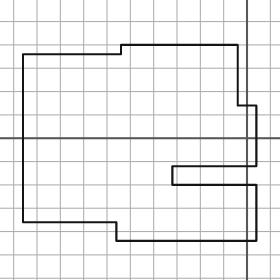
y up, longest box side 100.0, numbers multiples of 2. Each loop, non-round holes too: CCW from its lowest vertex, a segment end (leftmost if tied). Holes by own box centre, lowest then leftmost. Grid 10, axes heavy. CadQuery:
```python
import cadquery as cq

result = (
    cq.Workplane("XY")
    .moveTo(-56.0, -44.0)
    .lineTo(4.0, -44.0)
    .lineTo(4.0, -20.0)
    .lineTo(-32.0, -20.0)
    .lineTo(-32.0, -12.0)
    .lineTo(4.0, -12.0)
    .lineTo(4.0, 14.0)
    .lineTo(-4.0, 14.0)
    .lineTo(-4.0, 40.0)
    .lineTo(-54.0, 40.0)
    .lineTo(-54.0, 36.0)
    .lineTo(-96.0, 36.0)
    .lineTo(-96.0, -36.0)
    .lineTo(-56.0, -36.0)
    .close()
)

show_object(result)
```